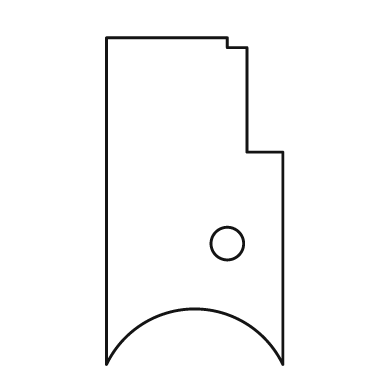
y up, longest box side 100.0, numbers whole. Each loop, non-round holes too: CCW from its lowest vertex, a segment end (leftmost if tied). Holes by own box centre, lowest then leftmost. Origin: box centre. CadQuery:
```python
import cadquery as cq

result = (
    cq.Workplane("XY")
    .moveTo(-27.0, -50.0)
    .threePointArc((0.0, -33.0), (27.0, -50.0))
    .lineTo(27.0, 15.0)
    .lineTo(16.0, 15.0)
    .lineTo(16.0, 47.0)
    .lineTo(10.0, 47.0)
    .lineTo(10.0, 50.0)
    .lineTo(-27.0, 50.0)
    .close()
    .moveTo(10.0, -13.0)
    .circle(5.0)
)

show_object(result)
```